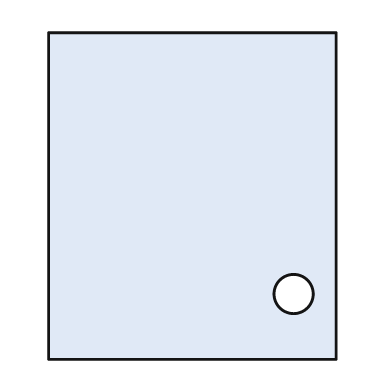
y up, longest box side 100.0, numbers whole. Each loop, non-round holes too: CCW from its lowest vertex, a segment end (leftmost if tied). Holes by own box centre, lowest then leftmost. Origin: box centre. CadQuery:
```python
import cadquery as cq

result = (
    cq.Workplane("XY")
    .moveTo(-44.0, -50.0)
    .lineTo(44.0, -50.0)
    .lineTo(44.0, 50.0)
    .lineTo(-44.0, 50.0)
    .close()
    .moveTo(31.0, -30.0)
    .circle(6.0)
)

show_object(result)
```